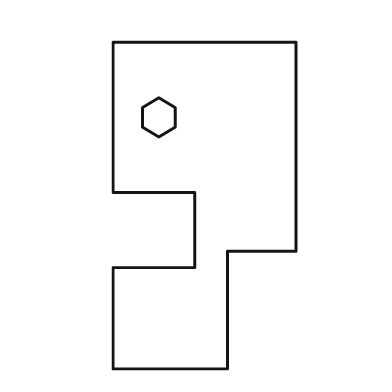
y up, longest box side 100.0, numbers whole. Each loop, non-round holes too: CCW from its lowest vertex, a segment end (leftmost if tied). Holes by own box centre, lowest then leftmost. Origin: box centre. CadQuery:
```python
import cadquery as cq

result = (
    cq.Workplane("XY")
    .moveTo(-28.0, -50.0)
    .lineTo(7.0, -50.0)
    .lineTo(7.0, -14.0)
    .lineTo(28.0, -14.0)
    .lineTo(28.0, 50.0)
    .lineTo(-28.0, 50.0)
    .lineTo(-28.0, 4.0)
    .lineTo(-3.0, 4.0)
    .lineTo(-3.0, -19.0)
    .lineTo(-28.0, -19.0)
    .close()
    .moveTo(-14.0, 21.0)
    .lineTo(-9.0, 24.0)
    .lineTo(-9.0, 30.0)
    .lineTo(-14.0, 33.0)
    .lineTo(-19.0, 30.0)
    .lineTo(-19.0, 24.0)
    .close()
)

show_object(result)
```